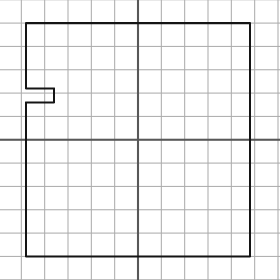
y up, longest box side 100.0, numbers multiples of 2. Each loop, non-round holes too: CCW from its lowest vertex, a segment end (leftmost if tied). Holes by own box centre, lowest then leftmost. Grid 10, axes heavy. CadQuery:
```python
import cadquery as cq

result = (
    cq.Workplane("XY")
    .moveTo(-48.0, -50.0)
    .lineTo(48.0, -50.0)
    .lineTo(48.0, 50.0)
    .lineTo(-48.0, 50.0)
    .lineTo(-48.0, 22.0)
    .lineTo(-36.0, 22.0)
    .lineTo(-36.0, 16.0)
    .lineTo(-48.0, 16.0)
    .close()
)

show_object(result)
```